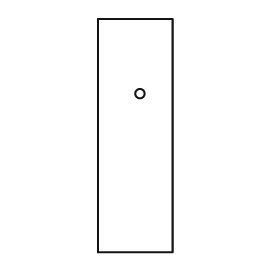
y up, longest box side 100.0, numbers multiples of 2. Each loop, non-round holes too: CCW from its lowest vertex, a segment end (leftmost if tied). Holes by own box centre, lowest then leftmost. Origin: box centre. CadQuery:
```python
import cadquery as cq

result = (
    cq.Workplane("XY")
    .moveTo(-16.0, -50.0)
    .lineTo(16.0, -50.0)
    .lineTo(16.0, 50.0)
    .lineTo(-16.0, 50.0)
    .close()
    .moveTo(2.0, 18.0)
    .circle(2.0)
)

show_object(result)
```